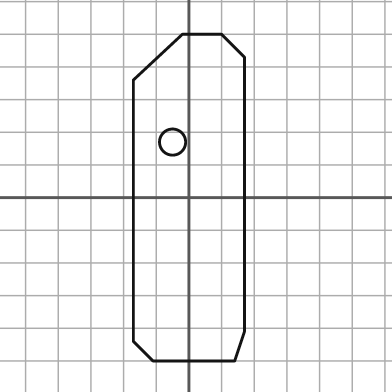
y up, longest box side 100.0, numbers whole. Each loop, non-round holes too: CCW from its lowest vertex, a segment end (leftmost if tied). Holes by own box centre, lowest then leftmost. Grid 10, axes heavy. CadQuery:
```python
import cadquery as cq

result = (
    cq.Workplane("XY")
    .moveTo(-11.0, -50.0)
    .lineTo(14.0, -50.0)
    .lineTo(17.0, -41.0)
    .lineTo(17.0, 43.0)
    .lineTo(10.0, 50.0)
    .lineTo(-2.0, 50.0)
    .lineTo(-17.0, 36.0)
    .lineTo(-17.0, -44.0)
    .close()
    .moveTo(-5.0, 17.0)
    .circle(4.0)
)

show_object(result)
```